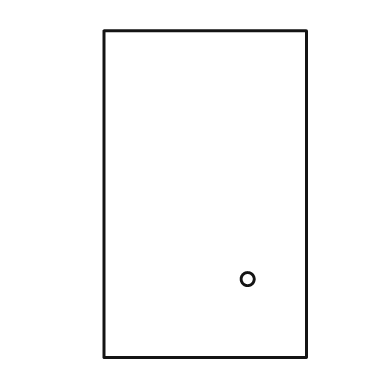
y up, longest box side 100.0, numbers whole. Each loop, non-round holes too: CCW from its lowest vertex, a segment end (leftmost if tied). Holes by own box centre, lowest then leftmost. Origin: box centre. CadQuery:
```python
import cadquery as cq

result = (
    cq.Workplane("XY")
    .moveTo(-31.0, -50.0)
    .lineTo(31.0, -50.0)
    .lineTo(31.0, 50.0)
    .lineTo(-31.0, 50.0)
    .close()
    .moveTo(13.0, -26.0)
    .circle(2.0)
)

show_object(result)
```